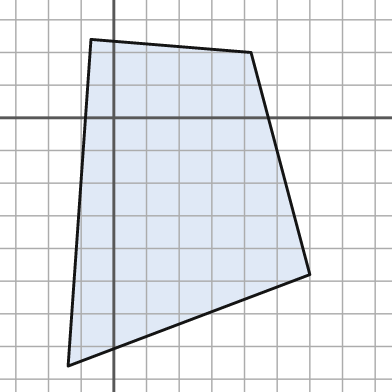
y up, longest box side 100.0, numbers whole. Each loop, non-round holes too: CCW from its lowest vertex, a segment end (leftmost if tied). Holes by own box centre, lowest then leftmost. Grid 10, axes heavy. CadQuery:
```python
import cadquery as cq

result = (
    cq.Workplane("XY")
    .moveTo(-14.0, -76.0)
    .lineTo(60.0, -48.0)
    .lineTo(42.0, 20.0)
    .lineTo(-7.0, 24.0)
    .close()
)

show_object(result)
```